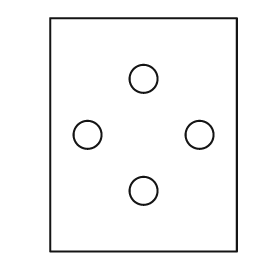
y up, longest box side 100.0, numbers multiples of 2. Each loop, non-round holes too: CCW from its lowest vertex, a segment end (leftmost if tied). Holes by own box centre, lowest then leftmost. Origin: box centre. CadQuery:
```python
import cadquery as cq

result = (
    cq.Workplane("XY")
    .moveTo(-40.0, -50.0)
    .lineTo(40.0, -50.0)
    .lineTo(40.0, 50.0)
    .lineTo(-40.0, 50.0)
    .close()
    .moveTo(0.0, -24.0)
    .circle(6.0)
    .moveTo(-24.0, 0.0)
    .circle(6.0)
    .moveTo(24.0, 0.0)
    .circle(6.0)
    .moveTo(0.0, 24.0)
    .circle(6.0)
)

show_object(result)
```